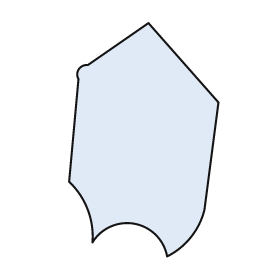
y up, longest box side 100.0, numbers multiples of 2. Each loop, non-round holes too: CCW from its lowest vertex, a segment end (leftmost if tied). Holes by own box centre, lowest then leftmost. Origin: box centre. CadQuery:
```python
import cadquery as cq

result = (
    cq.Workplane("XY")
    .moveTo(10.0, -50.0)
    .threePointArc((20.0, -42.0), (26.0, -30.0))
    .lineTo(32.0, 16.0)
    .lineTo(2.0, 50.0)
    .lineTo(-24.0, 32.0)
    .threePointArc((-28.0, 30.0), (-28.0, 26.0))
    .lineTo(-32.0, -18.0)
    .threePointArc((-24.0, -30.0), (-22.0, -44.0))
    .threePointArc((-4.0, -36.0), (10.0, -50.0))
    .close()
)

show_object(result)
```